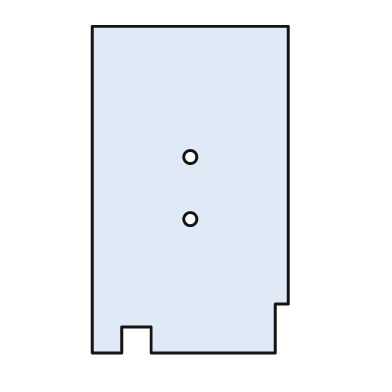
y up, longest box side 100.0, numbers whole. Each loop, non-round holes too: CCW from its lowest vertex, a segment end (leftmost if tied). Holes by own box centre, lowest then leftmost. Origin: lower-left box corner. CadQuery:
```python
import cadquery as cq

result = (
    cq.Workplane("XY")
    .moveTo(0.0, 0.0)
    .lineTo(9.0, 0.0)
    .lineTo(9.0, 8.0)
    .lineTo(18.0, 8.0)
    .lineTo(18.0, 0.0)
    .lineTo(56.0, 0.0)
    .lineTo(56.0, 15.0)
    .lineTo(60.0, 15.0)
    .lineTo(60.0, 100.0)
    .lineTo(0.0, 100.0)
    .close()
    .moveTo(30.0, 41.0)
    .circle(2.0)
    .moveTo(30.0, 60.0)
    .circle(2.0)
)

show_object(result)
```